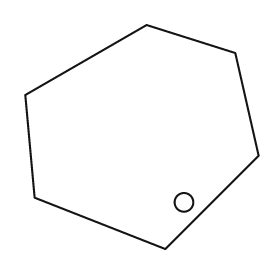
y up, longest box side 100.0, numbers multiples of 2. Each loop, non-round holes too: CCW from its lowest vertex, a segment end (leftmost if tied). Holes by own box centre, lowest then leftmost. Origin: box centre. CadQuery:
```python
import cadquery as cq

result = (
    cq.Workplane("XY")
    .moveTo(10.0, -48.0)
    .lineTo(50.0, -8.0)
    .lineTo(40.0, 36.0)
    .lineTo(2.0, 48.0)
    .lineTo(-50.0, 18.0)
    .lineTo(-46.0, -26.0)
    .close()
    .moveTo(18.0, -28.0)
    .circle(4.0)
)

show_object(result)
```